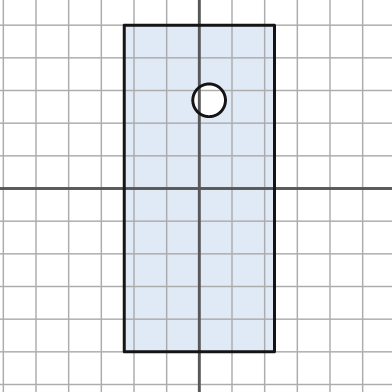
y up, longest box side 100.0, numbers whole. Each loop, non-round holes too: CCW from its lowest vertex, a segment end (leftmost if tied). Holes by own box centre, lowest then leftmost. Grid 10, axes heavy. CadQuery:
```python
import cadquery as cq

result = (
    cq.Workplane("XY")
    .moveTo(-23.0, -50.0)
    .lineTo(23.0, -50.0)
    .lineTo(23.0, 50.0)
    .lineTo(-23.0, 50.0)
    .close()
    .moveTo(3.0, 27.0)
    .circle(5.0)
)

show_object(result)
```